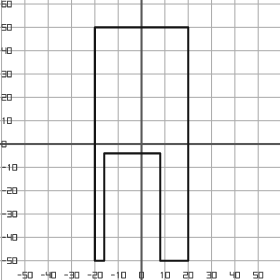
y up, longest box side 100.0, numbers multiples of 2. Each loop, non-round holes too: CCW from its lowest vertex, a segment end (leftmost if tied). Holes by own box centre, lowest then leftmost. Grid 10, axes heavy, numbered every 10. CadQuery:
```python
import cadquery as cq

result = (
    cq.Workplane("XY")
    .moveTo(-20.0, -50.0)
    .lineTo(-16.0, -50.0)
    .lineTo(-16.0, -4.0)
    .lineTo(8.0, -4.0)
    .lineTo(8.0, -50.0)
    .lineTo(20.0, -50.0)
    .lineTo(20.0, 50.0)
    .lineTo(-20.0, 50.0)
    .close()
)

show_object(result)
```